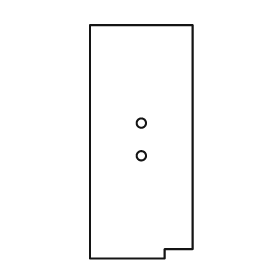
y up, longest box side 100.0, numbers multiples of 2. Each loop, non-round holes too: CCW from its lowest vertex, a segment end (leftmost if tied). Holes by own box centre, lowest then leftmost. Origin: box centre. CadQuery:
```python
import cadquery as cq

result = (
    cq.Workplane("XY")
    .moveTo(-22.0, -50.0)
    .lineTo(10.0, -50.0)
    .lineTo(10.0, -46.0)
    .lineTo(22.0, -46.0)
    .lineTo(22.0, 50.0)
    .lineTo(-22.0, 50.0)
    .close()
    .moveTo(0.0, -6.0)
    .circle(2.0)
    .moveTo(0.0, 8.0)
    .circle(2.0)
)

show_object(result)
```